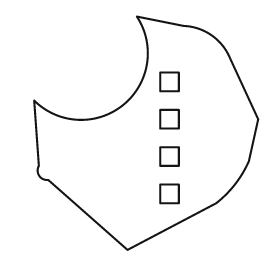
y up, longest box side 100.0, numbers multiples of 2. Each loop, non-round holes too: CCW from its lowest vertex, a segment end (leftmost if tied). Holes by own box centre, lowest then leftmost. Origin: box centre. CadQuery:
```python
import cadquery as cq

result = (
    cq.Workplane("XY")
    .moveTo(-8.0, -50.0)
    .lineTo(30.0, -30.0)
    .threePointArc((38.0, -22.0), (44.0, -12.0))
    .lineTo(48.0, 6.0)
    .lineTo(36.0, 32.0)
    .threePointArc((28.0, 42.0), (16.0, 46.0))
    .lineTo(-4.0, 50.0)
    .threePointArc((-10.0, 12.0), (-48.0, 14.0))
    .lineTo(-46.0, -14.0)
    .threePointArc((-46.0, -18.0), (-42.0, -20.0))
    .close()
    .moveTo(6.0, -30.0)
    .lineTo(14.0, -30.0)
    .lineTo(14.0, -22.0)
    .lineTo(6.0, -22.0)
    .close()
    .moveTo(6.0, -14.0)
    .lineTo(14.0, -14.0)
    .lineTo(14.0, -6.0)
    .lineTo(6.0, -6.0)
    .close()
    .moveTo(6.0, 2.0)
    .lineTo(14.0, 2.0)
    .lineTo(14.0, 10.0)
    .lineTo(6.0, 10.0)
    .close()
    .moveTo(6.0, 18.0)
    .lineTo(14.0, 18.0)
    .lineTo(14.0, 26.0)
    .lineTo(6.0, 26.0)
    .close()
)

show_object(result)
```